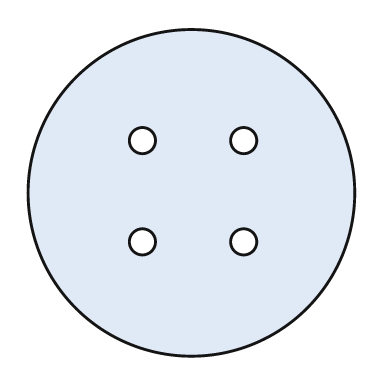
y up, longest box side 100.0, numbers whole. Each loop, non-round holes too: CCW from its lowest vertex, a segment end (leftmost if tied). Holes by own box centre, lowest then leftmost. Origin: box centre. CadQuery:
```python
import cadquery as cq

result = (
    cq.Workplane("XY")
    .moveTo(0.0, 0.0)
    .circle(50.0)
    .moveTo(-15.0, -15.0)
    .circle(4.0)
    .moveTo(16.0, -15.0)
    .circle(4.0)
    .moveTo(-15.0, 16.0)
    .circle(4.0)
    .moveTo(16.0, 16.0)
    .circle(4.0)
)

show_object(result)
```